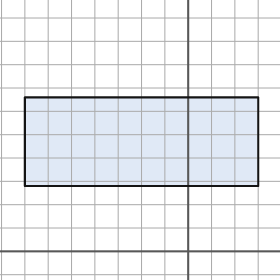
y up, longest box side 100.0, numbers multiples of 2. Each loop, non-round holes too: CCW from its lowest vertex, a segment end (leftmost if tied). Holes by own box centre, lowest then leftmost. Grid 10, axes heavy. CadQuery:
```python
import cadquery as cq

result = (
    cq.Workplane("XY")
    .moveTo(-70.0, 28.0)
    .lineTo(30.0, 28.0)
    .lineTo(30.0, 66.0)
    .lineTo(-70.0, 66.0)
    .close()
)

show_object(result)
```